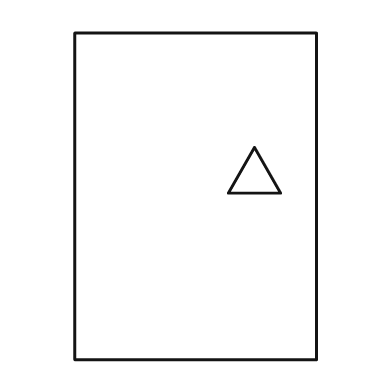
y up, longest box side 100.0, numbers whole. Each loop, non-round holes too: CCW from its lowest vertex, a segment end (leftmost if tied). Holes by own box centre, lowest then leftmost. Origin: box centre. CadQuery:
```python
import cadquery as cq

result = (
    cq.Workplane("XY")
    .moveTo(-37.0, -50.0)
    .lineTo(37.0, -50.0)
    .lineTo(37.0, 50.0)
    .lineTo(-37.0, 50.0)
    .close()
    .moveTo(10.0, 1.0)
    .lineTo(26.0, 1.0)
    .lineTo(18.0, 15.0)
    .close()
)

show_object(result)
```